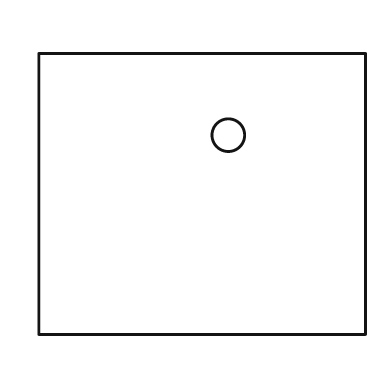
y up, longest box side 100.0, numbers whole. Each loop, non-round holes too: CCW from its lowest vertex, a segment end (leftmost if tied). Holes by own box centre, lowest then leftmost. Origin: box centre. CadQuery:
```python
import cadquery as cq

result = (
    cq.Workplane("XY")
    .moveTo(-50.0, -43.0)
    .lineTo(50.0, -43.0)
    .lineTo(50.0, 43.0)
    .lineTo(-50.0, 43.0)
    .close()
    .moveTo(8.0, 18.0)
    .circle(5.0)
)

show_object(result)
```